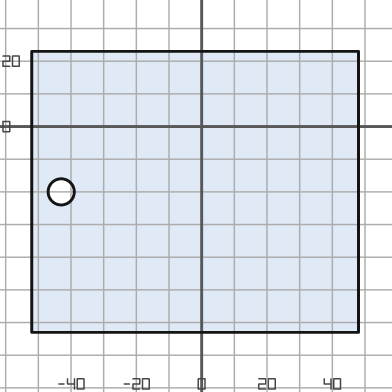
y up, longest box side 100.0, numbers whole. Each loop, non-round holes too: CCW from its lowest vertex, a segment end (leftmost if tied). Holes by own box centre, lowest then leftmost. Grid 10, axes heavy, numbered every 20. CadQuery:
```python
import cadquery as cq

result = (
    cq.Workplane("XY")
    .moveTo(-52.0, -63.0)
    .lineTo(48.0, -63.0)
    .lineTo(48.0, 23.0)
    .lineTo(-52.0, 23.0)
    .close()
    .moveTo(-43.0, -20.0)
    .circle(4.0)
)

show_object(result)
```